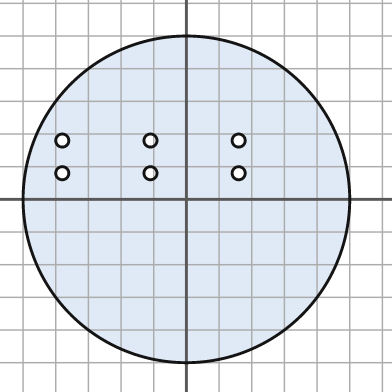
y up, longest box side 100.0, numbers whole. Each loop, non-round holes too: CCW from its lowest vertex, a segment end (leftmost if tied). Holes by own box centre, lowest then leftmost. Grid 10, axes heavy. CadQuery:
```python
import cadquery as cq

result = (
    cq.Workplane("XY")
    .moveTo(0.0, 0.0)
    .circle(50.0)
    .moveTo(-38.0, 8.0)
    .circle(2.0)
    .moveTo(-11.0, 8.0)
    .circle(2.0)
    .moveTo(16.0, 8.0)
    .circle(2.0)
    .moveTo(-38.0, 18.0)
    .circle(2.0)
    .moveTo(-11.0, 18.0)
    .circle(2.0)
    .moveTo(16.0, 18.0)
    .circle(2.0)
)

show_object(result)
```